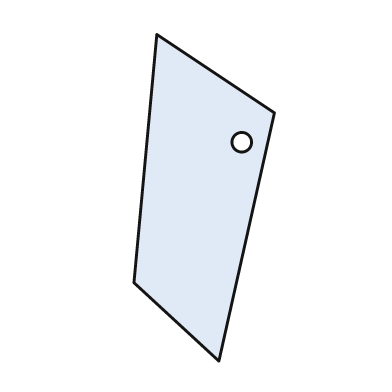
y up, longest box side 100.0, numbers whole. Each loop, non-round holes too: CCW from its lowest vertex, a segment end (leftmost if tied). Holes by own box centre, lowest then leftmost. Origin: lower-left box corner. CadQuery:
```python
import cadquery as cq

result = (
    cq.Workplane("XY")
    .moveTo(26.0, 0.0)
    .lineTo(43.0, 76.0)
    .lineTo(7.0, 100.0)
    .lineTo(0.0, 24.0)
    .close()
    .moveTo(33.0, 67.0)
    .circle(3.0)
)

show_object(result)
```